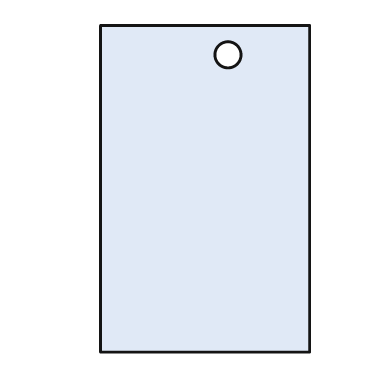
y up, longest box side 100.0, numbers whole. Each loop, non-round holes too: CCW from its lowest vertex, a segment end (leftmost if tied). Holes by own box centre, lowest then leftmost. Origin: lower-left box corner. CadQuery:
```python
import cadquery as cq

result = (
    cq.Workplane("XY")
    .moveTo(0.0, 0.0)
    .lineTo(64.0, 0.0)
    .lineTo(64.0, 100.0)
    .lineTo(0.0, 100.0)
    .close()
    .moveTo(39.0, 91.0)
    .circle(4.0)
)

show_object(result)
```